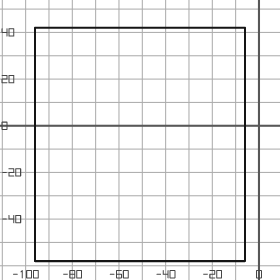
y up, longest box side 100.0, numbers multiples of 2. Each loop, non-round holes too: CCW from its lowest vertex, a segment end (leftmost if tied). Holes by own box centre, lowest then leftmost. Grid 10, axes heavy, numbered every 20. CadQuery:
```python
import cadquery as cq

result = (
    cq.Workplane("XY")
    .moveTo(-96.0, -58.0)
    .lineTo(-6.0, -58.0)
    .lineTo(-6.0, 42.0)
    .lineTo(-96.0, 42.0)
    .close()
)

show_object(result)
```